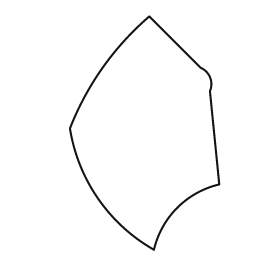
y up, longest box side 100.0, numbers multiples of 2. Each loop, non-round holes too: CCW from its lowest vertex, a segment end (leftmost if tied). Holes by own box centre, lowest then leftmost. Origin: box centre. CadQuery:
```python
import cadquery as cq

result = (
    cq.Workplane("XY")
    .moveTo(4.0, -50.0)
    .threePointArc((14.0, -32.0), (32.0, -22.0))
    .lineTo(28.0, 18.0)
    .threePointArc((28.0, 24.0), (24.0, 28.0))
    .lineTo(2.0, 50.0)
    .threePointArc((-18.0, 28.0), (-32.0, 2.0))
    .threePointArc((-20.0, -28.0), (4.0, -50.0))
    .close()
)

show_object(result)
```